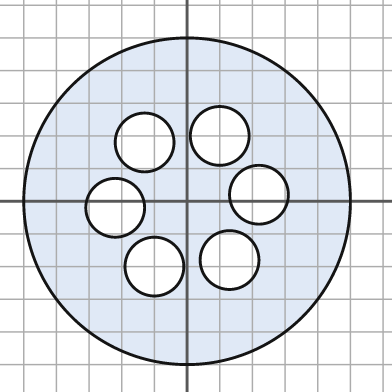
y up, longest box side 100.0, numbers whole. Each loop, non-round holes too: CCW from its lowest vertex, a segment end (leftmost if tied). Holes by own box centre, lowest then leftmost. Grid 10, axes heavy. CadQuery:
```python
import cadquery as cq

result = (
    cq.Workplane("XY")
    .moveTo(0.0, 0.0)
    .circle(50.0)
    .moveTo(-10.0, -20.0)
    .circle(9.0)
    .moveTo(13.0, -18.0)
    .circle(9.0)
    .moveTo(-22.0, -2.0)
    .circle(9.0)
    .moveTo(22.0, 2.0)
    .circle(9.0)
    .moveTo(-13.0, 18.0)
    .circle(9.0)
    .moveTo(10.0, 20.0)
    .circle(9.0)
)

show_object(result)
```